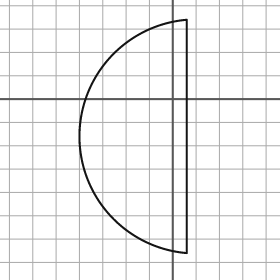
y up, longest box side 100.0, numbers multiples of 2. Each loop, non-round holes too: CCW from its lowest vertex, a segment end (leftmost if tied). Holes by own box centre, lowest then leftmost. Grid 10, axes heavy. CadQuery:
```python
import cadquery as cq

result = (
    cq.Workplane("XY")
    .moveTo(6.0, -66.0)
    .lineTo(6.0, 34.0)
    .threePointArc((-40.0, -16.0), (6.0, -66.0))
    .close()
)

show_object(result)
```